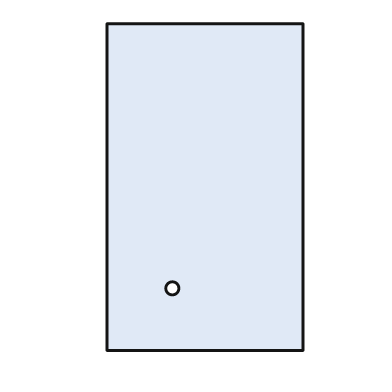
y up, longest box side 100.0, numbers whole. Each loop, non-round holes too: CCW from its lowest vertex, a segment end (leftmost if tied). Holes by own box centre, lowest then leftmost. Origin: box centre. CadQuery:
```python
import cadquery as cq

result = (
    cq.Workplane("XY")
    .moveTo(-30.0, -50.0)
    .lineTo(30.0, -50.0)
    .lineTo(30.0, 50.0)
    .lineTo(-30.0, 50.0)
    .close()
    .moveTo(-10.0, -31.0)
    .circle(2.0)
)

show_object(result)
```